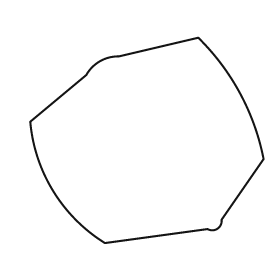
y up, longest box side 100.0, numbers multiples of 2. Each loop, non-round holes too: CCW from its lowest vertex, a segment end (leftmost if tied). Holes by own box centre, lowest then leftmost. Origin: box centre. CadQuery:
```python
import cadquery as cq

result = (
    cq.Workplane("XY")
    .moveTo(-18.0, -44.0)
    .lineTo(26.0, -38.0)
    .threePointArc((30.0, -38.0), (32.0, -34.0))
    .lineTo(50.0, -8.0)
    .threePointArc((40.0, 20.0), (22.0, 44.0))
    .lineTo(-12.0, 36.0)
    .threePointArc((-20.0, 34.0), (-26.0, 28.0))
    .lineTo(-50.0, 8.0)
    .threePointArc((-40.0, -22.0), (-18.0, -44.0))
    .close()
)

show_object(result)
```